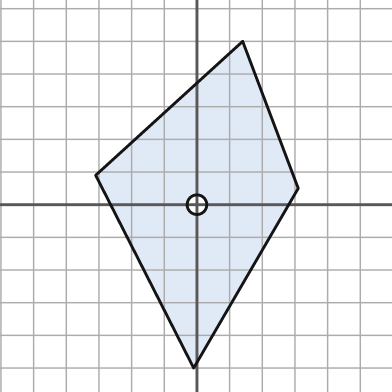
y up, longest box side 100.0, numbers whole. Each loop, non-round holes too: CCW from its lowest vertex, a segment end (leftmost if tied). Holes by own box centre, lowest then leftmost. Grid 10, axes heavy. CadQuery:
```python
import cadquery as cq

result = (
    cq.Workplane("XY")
    .moveTo(-1.0, -50.0)
    .lineTo(31.0, 5.0)
    .lineTo(14.0, 50.0)
    .lineTo(-31.0, 9.0)
    .close()
    .moveTo(0.0, 0.0)
    .circle(3.0)
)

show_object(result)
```